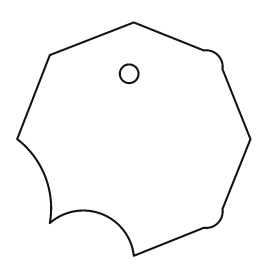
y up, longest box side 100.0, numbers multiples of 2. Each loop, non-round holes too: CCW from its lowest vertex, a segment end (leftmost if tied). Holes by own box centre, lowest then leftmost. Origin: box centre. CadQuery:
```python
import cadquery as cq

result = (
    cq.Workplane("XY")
    .moveTo(0.0, -50.0)
    .lineTo(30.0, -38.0)
    .threePointArc((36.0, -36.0), (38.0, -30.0))
    .lineTo(50.0, 0.0)
    .lineTo(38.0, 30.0)
    .threePointArc((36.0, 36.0), (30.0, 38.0))
    .lineTo(0.0, 50.0)
    .lineTo(-36.0, 36.0)
    .lineTo(-50.0, 0.0)
    .threePointArc((-38.0, -16.0), (-36.0, -36.0))
    .threePointArc((-14.0, -32.0), (0.0, -50.0))
    .close()
    .moveTo(-2.0, 28.0)
    .circle(4.0)
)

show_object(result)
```